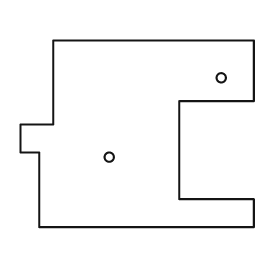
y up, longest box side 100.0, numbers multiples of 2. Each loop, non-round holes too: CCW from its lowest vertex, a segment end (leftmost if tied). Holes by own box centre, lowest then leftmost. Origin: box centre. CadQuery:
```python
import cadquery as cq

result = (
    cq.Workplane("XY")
    .moveTo(-42.0, -40.0)
    .lineTo(50.0, -40.0)
    .lineTo(50.0, -28.0)
    .lineTo(18.0, -28.0)
    .lineTo(18.0, 14.0)
    .lineTo(50.0, 14.0)
    .lineTo(50.0, 40.0)
    .lineTo(-36.0, 40.0)
    .lineTo(-36.0, 4.0)
    .lineTo(-50.0, 4.0)
    .lineTo(-50.0, -8.0)
    .lineTo(-42.0, -8.0)
    .close()
    .moveTo(-12.0, -10.0)
    .circle(2.0)
    .moveTo(36.0, 24.0)
    .circle(2.0)
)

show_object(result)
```